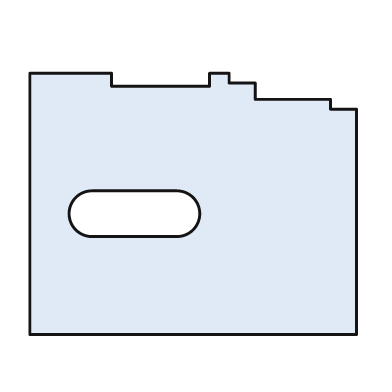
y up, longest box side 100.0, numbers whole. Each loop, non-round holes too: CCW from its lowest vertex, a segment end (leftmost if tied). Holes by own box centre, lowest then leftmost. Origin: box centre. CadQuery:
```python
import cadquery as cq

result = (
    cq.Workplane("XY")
    .moveTo(-50.0, -40.0)
    .lineTo(50.0, -40.0)
    .lineTo(50.0, 29.0)
    .lineTo(42.0, 29.0)
    .lineTo(42.0, 32.0)
    .lineTo(19.0, 32.0)
    .lineTo(19.0, 37.0)
    .lineTo(11.0, 37.0)
    .lineTo(11.0, 40.0)
    .lineTo(5.0, 40.0)
    .lineTo(5.0, 36.0)
    .lineTo(-25.0, 36.0)
    .lineTo(-25.0, 40.0)
    .lineTo(-50.0, 40.0)
    .close()
    .moveTo(-31.0, -10.0)
    .lineTo(-5.0, -10.0)
    .threePointArc((2.0, -3.0), (-5.0, 4.0))
    .lineTo(-31.0, 4.0)
    .threePointArc((-38.0, -3.0), (-31.0, -10.0))
    .close()
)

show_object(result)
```